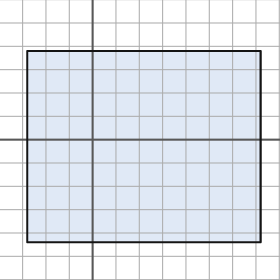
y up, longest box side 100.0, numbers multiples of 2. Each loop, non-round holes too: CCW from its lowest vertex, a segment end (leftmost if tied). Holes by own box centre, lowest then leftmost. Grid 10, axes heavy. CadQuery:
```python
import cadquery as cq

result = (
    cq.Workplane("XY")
    .moveTo(-28.0, -44.0)
    .lineTo(72.0, -44.0)
    .lineTo(72.0, 38.0)
    .lineTo(-28.0, 38.0)
    .close()
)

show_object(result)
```